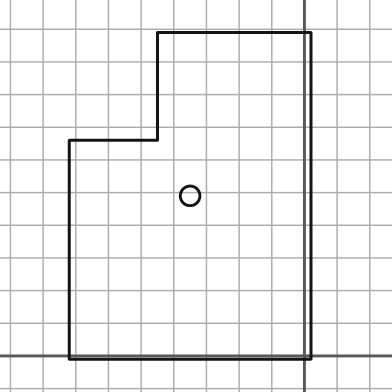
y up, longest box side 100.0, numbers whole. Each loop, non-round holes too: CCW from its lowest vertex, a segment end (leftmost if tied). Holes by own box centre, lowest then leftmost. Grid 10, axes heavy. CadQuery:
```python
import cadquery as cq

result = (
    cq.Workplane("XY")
    .moveTo(-72.0, -1.0)
    .lineTo(2.0, -1.0)
    .lineTo(2.0, 99.0)
    .lineTo(-45.0, 99.0)
    .lineTo(-45.0, 66.0)
    .lineTo(-72.0, 66.0)
    .close()
    .moveTo(-35.0, 49.0)
    .circle(3.0)
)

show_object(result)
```